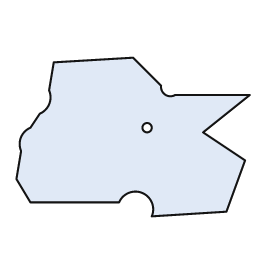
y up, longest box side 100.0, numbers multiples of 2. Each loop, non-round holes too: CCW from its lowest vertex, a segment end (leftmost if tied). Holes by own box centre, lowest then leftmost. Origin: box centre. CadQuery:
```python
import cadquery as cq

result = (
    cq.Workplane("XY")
    .moveTo(8.0, -34.0)
    .lineTo(40.0, -32.0)
    .lineTo(48.0, -10.0)
    .lineTo(30.0, 2.0)
    .lineTo(50.0, 18.0)
    .lineTo(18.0, 18.0)
    .threePointArc((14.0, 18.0), (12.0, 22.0))
    .lineTo(0.0, 34.0)
    .lineTo(-34.0, 32.0)
    .lineTo(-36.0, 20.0)
    .threePointArc((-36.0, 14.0), (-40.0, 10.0))
    .lineTo(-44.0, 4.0)
    .threePointArc((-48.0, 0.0), (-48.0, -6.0))
    .lineTo(-50.0, -18.0)
    .lineTo(-44.0, -28.0)
    .lineTo(-6.0, -28.0)
    .threePointArc((4.0, -24.0), (8.0, -34.0))
    .close()
    .moveTo(6.0, 4.0)
    .circle(2.0)
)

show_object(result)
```